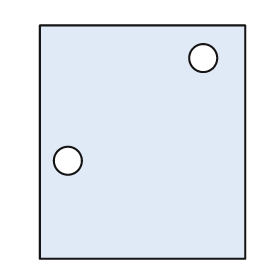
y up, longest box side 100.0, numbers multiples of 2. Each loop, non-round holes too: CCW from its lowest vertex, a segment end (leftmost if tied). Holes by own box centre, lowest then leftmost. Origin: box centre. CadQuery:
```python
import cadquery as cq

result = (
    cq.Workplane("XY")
    .moveTo(-44.0, -50.0)
    .lineTo(44.0, -50.0)
    .lineTo(44.0, 50.0)
    .lineTo(-44.0, 50.0)
    .close()
    .moveTo(-32.0, -8.0)
    .circle(6.0)
    .moveTo(26.0, 36.0)
    .circle(6.0)
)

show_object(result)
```